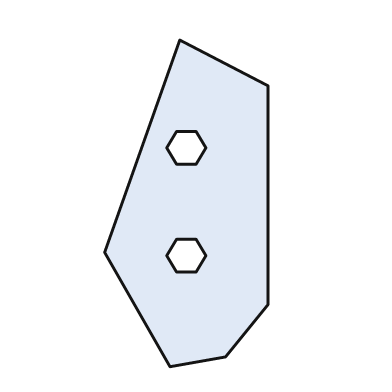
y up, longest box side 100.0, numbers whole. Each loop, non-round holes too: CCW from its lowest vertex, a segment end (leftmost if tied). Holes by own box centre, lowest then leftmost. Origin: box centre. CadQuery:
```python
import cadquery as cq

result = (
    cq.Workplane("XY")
    .moveTo(-5.0, -50.0)
    .lineTo(12.0, -47.0)
    .lineTo(25.0, -31.0)
    .lineTo(25.0, 36.0)
    .lineTo(-2.0, 50.0)
    .lineTo(-25.0, -15.0)
    .close()
    .moveTo(-3.0, -21.0)
    .lineTo(3.0, -21.0)
    .lineTo(6.0, -16.0)
    .lineTo(3.0, -11.0)
    .lineTo(-3.0, -11.0)
    .lineTo(-6.0, -16.0)
    .close()
    .moveTo(-3.0, 12.0)
    .lineTo(3.0, 12.0)
    .lineTo(6.0, 17.0)
    .lineTo(3.0, 22.0)
    .lineTo(-3.0, 22.0)
    .lineTo(-6.0, 17.0)
    .close()
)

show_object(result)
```